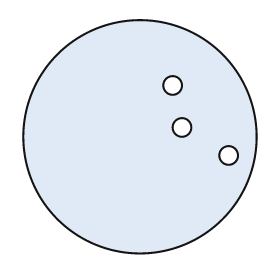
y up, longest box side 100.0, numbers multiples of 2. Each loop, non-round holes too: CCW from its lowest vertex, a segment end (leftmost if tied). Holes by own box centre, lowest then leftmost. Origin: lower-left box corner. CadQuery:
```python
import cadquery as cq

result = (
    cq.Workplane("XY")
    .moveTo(50.0, 50.0)
    .circle(50.0)
    .moveTo(88.0, 42.0)
    .circle(4.0)
    .moveTo(68.0, 54.0)
    .circle(4.0)
    .moveTo(64.0, 72.0)
    .circle(4.0)
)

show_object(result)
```